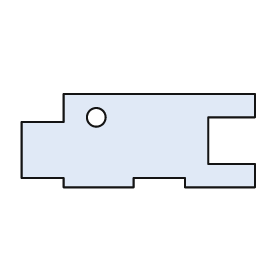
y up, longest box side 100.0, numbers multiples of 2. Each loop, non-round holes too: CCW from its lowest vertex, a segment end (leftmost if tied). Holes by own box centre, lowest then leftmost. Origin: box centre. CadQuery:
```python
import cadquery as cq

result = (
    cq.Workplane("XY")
    .moveTo(-32.0, -20.0)
    .lineTo(-2.0, -20.0)
    .lineTo(-2.0, -16.0)
    .lineTo(20.0, -16.0)
    .lineTo(20.0, -20.0)
    .lineTo(50.0, -20.0)
    .lineTo(50.0, -10.0)
    .lineTo(30.0, -10.0)
    .lineTo(30.0, 10.0)
    .lineTo(50.0, 10.0)
    .lineTo(50.0, 20.0)
    .lineTo(-32.0, 20.0)
    .lineTo(-32.0, 8.0)
    .lineTo(-50.0, 8.0)
    .lineTo(-50.0, -16.0)
    .lineTo(-32.0, -16.0)
    .close()
    .moveTo(-18.0, 10.0)
    .circle(4.0)
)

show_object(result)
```